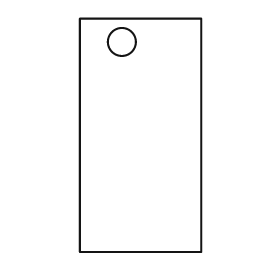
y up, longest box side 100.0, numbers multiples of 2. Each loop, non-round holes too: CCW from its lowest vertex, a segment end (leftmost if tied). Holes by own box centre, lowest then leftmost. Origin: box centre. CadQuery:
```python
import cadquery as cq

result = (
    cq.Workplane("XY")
    .moveTo(-26.0, -50.0)
    .lineTo(26.0, -50.0)
    .lineTo(26.0, 50.0)
    .lineTo(-26.0, 50.0)
    .close()
    .moveTo(-8.0, 40.0)
    .circle(6.0)
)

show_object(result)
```